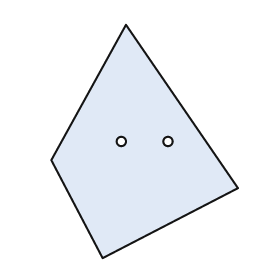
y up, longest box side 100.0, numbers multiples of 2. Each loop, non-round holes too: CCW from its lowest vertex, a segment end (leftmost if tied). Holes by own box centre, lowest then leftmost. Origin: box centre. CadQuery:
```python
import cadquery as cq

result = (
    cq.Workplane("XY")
    .moveTo(-18.0, -50.0)
    .lineTo(40.0, -20.0)
    .lineTo(-8.0, 50.0)
    .lineTo(-40.0, -8.0)
    .close()
    .moveTo(-10.0, 0.0)
    .circle(2.0)
    .moveTo(10.0, 0.0)
    .circle(2.0)
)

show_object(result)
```